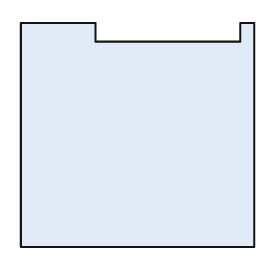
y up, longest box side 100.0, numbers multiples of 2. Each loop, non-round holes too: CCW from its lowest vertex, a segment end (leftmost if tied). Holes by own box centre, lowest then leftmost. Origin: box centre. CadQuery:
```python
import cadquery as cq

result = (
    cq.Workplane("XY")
    .moveTo(-50.0, -48.0)
    .lineTo(50.0, -48.0)
    .lineTo(50.0, 48.0)
    .lineTo(44.0, 48.0)
    .lineTo(44.0, 40.0)
    .lineTo(-18.0, 40.0)
    .lineTo(-18.0, 48.0)
    .lineTo(-50.0, 48.0)
    .close()
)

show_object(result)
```